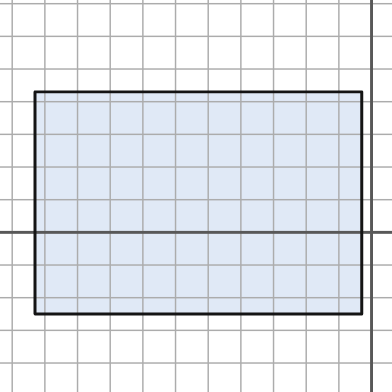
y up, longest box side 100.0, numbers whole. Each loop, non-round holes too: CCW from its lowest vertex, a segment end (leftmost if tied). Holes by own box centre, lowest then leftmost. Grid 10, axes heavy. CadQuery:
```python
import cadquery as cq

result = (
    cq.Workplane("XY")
    .moveTo(-103.0, -25.0)
    .lineTo(-3.0, -25.0)
    .lineTo(-3.0, 43.0)
    .lineTo(-103.0, 43.0)
    .close()
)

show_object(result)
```